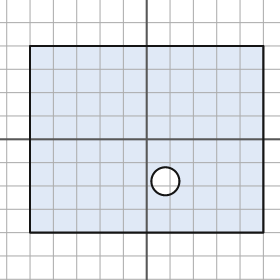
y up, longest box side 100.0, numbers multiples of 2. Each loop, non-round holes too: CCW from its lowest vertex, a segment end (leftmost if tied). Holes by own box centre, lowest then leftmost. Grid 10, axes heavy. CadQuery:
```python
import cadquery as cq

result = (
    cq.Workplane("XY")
    .moveTo(-50.0, -40.0)
    .lineTo(50.0, -40.0)
    .lineTo(50.0, 40.0)
    .lineTo(-50.0, 40.0)
    .close()
    .moveTo(8.0, -18.0)
    .circle(6.0)
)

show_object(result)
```